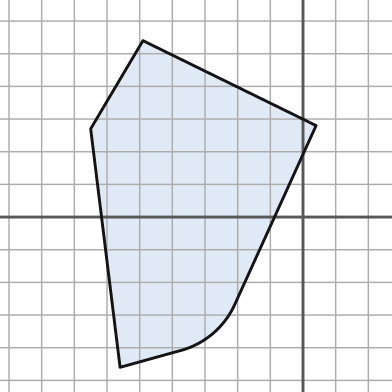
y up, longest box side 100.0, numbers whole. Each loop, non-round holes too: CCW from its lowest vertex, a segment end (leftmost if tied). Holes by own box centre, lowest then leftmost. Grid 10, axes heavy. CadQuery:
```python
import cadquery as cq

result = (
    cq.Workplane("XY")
    .moveTo(-56.0, -46.0)
    .lineTo(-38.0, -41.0)
    .threePointArc((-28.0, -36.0), (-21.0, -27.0))
    .lineTo(4.0, 28.0)
    .lineTo(-49.0, 54.0)
    .lineTo(-65.0, 27.0)
    .close()
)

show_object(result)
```